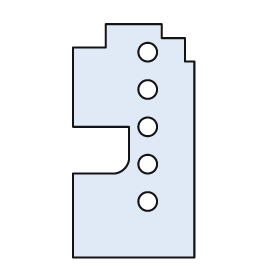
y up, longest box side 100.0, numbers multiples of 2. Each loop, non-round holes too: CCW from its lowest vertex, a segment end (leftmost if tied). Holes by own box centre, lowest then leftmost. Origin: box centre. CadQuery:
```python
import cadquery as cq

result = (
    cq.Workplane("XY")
    .moveTo(-26.0, -50.0)
    .lineTo(26.0, -50.0)
    .lineTo(26.0, 34.0)
    .lineTo(22.0, 34.0)
    .lineTo(22.0, 44.0)
    .lineTo(12.0, 44.0)
    .lineTo(12.0, 50.0)
    .lineTo(-12.0, 50.0)
    .lineTo(-12.0, 40.0)
    .lineTo(-26.0, 40.0)
    .lineTo(-26.0, 6.0)
    .lineTo(-2.0, 6.0)
    .lineTo(-2.0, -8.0)
    .threePointArc((-4.0, -12.0), (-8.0, -14.0))
    .lineTo(-26.0, -14.0)
    .close()
    .moveTo(6.0, -26.0)
    .circle(4.0)
    .moveTo(6.0, -10.0)
    .circle(4.0)
    .moveTo(6.0, 6.0)
    .circle(4.0)
    .moveTo(6.0, 22.0)
    .circle(4.0)
    .moveTo(6.0, 38.0)
    .circle(4.0)
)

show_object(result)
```